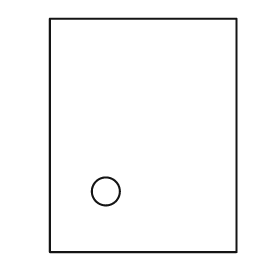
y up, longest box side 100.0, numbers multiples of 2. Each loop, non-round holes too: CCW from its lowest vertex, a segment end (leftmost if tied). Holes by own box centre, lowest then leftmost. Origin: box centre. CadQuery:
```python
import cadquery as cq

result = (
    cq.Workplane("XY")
    .moveTo(-40.0, -50.0)
    .lineTo(40.0, -50.0)
    .lineTo(40.0, 50.0)
    .lineTo(-40.0, 50.0)
    .close()
    .moveTo(-16.0, -24.0)
    .circle(6.0)
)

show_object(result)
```